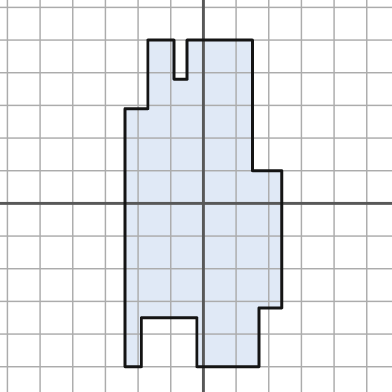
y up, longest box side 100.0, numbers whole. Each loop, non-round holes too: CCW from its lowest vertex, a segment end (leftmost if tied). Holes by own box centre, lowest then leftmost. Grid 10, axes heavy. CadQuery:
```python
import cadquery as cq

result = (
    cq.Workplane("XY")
    .moveTo(-24.0, -50.0)
    .lineTo(-19.0, -50.0)
    .lineTo(-19.0, -35.0)
    .lineTo(-2.0, -35.0)
    .lineTo(-2.0, -50.0)
    .lineTo(17.0, -50.0)
    .lineTo(17.0, -32.0)
    .lineTo(24.0, -32.0)
    .lineTo(24.0, 10.0)
    .lineTo(15.0, 10.0)
    .lineTo(15.0, 50.0)
    .lineTo(-5.0, 50.0)
    .lineTo(-5.0, 38.0)
    .lineTo(-9.0, 38.0)
    .lineTo(-9.0, 50.0)
    .lineTo(-17.0, 50.0)
    .lineTo(-17.0, 29.0)
    .lineTo(-24.0, 29.0)
    .close()
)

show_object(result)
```